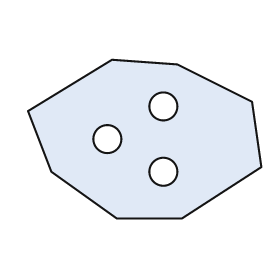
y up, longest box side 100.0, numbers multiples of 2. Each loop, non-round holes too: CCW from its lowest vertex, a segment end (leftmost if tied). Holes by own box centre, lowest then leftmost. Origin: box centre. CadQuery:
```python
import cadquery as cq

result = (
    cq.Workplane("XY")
    .moveTo(-12.0, -34.0)
    .lineTo(16.0, -34.0)
    .lineTo(50.0, -12.0)
    .lineTo(46.0, 16.0)
    .lineTo(14.0, 32.0)
    .lineTo(-14.0, 34.0)
    .lineTo(-50.0, 12.0)
    .lineTo(-40.0, -14.0)
    .close()
    .moveTo(8.0, -14.0)
    .circle(6.0)
    .moveTo(-16.0, 0.0)
    .circle(6.0)
    .moveTo(8.0, 14.0)
    .circle(6.0)
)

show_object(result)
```